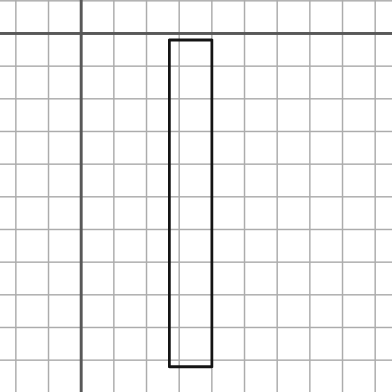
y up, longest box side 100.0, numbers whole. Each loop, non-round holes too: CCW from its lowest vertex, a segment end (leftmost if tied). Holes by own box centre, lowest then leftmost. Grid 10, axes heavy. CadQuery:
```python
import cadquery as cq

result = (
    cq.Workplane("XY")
    .moveTo(27.0, -102.0)
    .lineTo(40.0, -102.0)
    .lineTo(40.0, -2.0)
    .lineTo(27.0, -2.0)
    .close()
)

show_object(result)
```